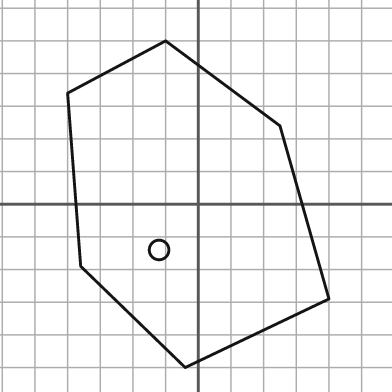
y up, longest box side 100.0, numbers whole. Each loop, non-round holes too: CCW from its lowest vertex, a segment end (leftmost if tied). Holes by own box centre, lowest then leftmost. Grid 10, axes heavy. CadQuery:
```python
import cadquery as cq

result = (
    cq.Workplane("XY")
    .moveTo(-4.0, -50.0)
    .lineTo(40.0, -29.0)
    .lineTo(25.0, 24.0)
    .lineTo(-10.0, 50.0)
    .lineTo(-40.0, 34.0)
    .lineTo(-36.0, -19.0)
    .close()
    .moveTo(-12.0, -14.0)
    .circle(3.0)
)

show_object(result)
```